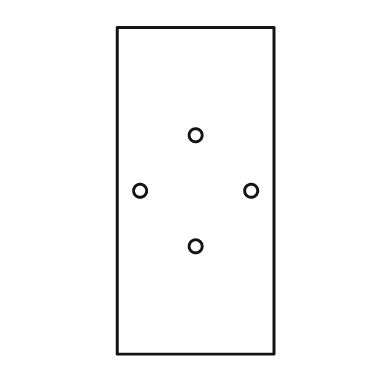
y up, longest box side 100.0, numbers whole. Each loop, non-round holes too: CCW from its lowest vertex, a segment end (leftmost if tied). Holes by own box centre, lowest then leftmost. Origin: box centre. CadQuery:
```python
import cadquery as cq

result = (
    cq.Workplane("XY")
    .moveTo(-24.0, -50.0)
    .lineTo(24.0, -50.0)
    .lineTo(24.0, 50.0)
    .lineTo(-24.0, 50.0)
    .close()
    .moveTo(0.0, -17.0)
    .circle(2.0)
    .moveTo(-17.0, 0.0)
    .circle(2.0)
    .moveTo(17.0, 0.0)
    .circle(2.0)
    .moveTo(0.0, 17.0)
    .circle(2.0)
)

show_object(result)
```